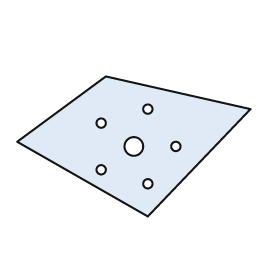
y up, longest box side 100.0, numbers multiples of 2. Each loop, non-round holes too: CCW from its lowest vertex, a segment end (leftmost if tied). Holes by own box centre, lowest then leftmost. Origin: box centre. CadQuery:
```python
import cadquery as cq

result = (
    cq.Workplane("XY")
    .moveTo(6.0, -30.0)
    .lineTo(50.0, 16.0)
    .lineTo(-12.0, 30.0)
    .lineTo(-50.0, 2.0)
    .close()
    .moveTo(6.0, -16.0)
    .circle(2.0)
    .moveTo(-14.0, -10.0)
    .circle(2.0)
    .moveTo(0.0, 0.0)
    .circle(4.0)
    .moveTo(18.0, 0.0)
    .circle(2.0)
    .moveTo(-14.0, 10.0)
    .circle(2.0)
    .moveTo(6.0, 16.0)
    .circle(2.0)
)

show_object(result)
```